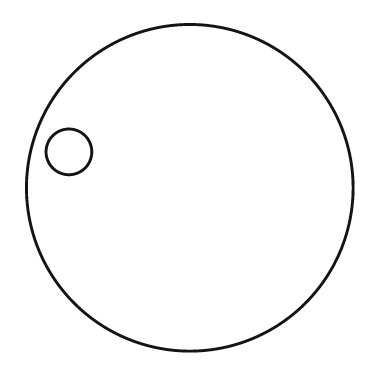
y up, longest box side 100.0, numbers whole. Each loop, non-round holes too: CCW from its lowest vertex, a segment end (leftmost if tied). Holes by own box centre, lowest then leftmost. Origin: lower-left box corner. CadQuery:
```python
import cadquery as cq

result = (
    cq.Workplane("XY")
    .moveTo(50.0, 50.0)
    .circle(50.0)
    .moveTo(13.0, 61.0)
    .circle(7.0)
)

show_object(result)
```